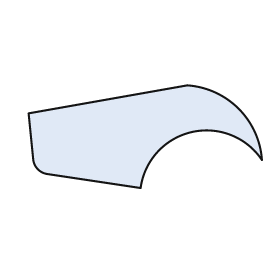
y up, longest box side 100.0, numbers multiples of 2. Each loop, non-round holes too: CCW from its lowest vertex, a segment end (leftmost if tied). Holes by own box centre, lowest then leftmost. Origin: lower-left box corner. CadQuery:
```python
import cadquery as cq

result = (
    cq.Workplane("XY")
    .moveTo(48.0, 0.0)
    .threePointArc((70.0, 24.0), (100.0, 12.0))
    .threePointArc((90.0, 34.0), (68.0, 44.0))
    .lineTo(0.0, 32.0)
    .lineTo(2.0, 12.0)
    .threePointArc((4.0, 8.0), (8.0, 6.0))
    .close()
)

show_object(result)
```